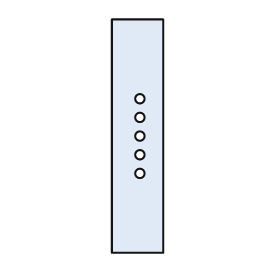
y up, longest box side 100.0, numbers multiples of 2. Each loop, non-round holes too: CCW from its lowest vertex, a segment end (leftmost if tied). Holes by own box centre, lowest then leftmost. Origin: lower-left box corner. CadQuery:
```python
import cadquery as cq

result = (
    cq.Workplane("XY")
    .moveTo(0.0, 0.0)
    .lineTo(22.0, 0.0)
    .lineTo(22.0, 100.0)
    .lineTo(0.0, 100.0)
    .close()
    .moveTo(12.0, 34.0)
    .circle(2.0)
    .moveTo(12.0, 42.0)
    .circle(2.0)
    .moveTo(12.0, 50.0)
    .circle(2.0)
    .moveTo(12.0, 58.0)
    .circle(2.0)
    .moveTo(12.0, 66.0)
    .circle(2.0)
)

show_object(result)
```